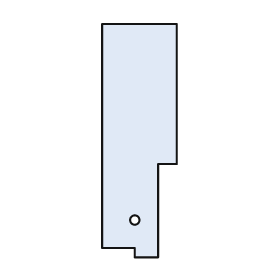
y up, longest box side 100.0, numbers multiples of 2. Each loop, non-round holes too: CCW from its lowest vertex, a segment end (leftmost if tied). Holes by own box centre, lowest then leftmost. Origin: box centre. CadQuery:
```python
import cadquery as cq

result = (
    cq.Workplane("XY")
    .moveTo(-2.0, -50.0)
    .lineTo(8.0, -50.0)
    .lineTo(8.0, -10.0)
    .lineTo(16.0, -10.0)
    .lineTo(16.0, 50.0)
    .lineTo(-16.0, 50.0)
    .lineTo(-16.0, -46.0)
    .lineTo(-2.0, -46.0)
    .close()
    .moveTo(-2.0, -34.0)
    .circle(2.0)
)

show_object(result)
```